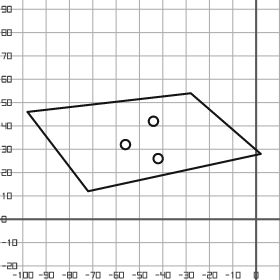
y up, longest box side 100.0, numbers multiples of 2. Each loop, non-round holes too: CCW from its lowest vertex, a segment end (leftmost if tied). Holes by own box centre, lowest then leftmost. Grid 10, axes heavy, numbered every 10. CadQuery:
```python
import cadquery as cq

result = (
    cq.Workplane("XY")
    .moveTo(-72.0, 12.0)
    .lineTo(2.0, 28.0)
    .lineTo(-28.0, 54.0)
    .lineTo(-98.0, 46.0)
    .close()
    .moveTo(-42.0, 26.0)
    .circle(2.0)
    .moveTo(-56.0, 32.0)
    .circle(2.0)
    .moveTo(-44.0, 42.0)
    .circle(2.0)
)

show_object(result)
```